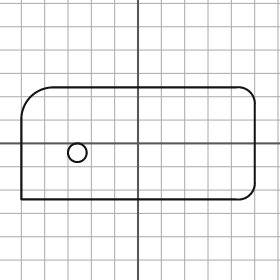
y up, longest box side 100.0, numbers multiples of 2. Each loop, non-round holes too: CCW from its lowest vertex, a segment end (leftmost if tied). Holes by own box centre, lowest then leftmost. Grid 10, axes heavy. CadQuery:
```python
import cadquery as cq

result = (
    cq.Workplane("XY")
    .moveTo(-50.0, -24.0)
    .lineTo(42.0, -24.0)
    .threePointArc((48.0, -22.0), (50.0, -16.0))
    .lineTo(50.0, 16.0)
    .threePointArc((48.0, 22.0), (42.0, 24.0))
    .lineTo(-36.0, 24.0)
    .threePointArc((-46.0, 20.0), (-50.0, 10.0))
    .close()
    .moveTo(-26.0, -4.0)
    .circle(4.0)
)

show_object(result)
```